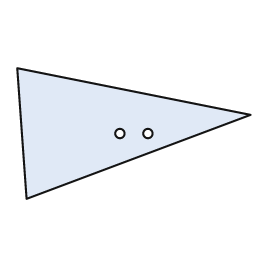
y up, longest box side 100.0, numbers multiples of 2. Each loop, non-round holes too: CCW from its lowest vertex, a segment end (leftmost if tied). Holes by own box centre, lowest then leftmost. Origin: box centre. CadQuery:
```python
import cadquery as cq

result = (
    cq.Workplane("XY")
    .moveTo(-46.0, -28.0)
    .lineTo(50.0, 8.0)
    .lineTo(-50.0, 28.0)
    .close()
    .moveTo(-6.0, 0.0)
    .circle(2.0)
    .moveTo(6.0, 0.0)
    .circle(2.0)
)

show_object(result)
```